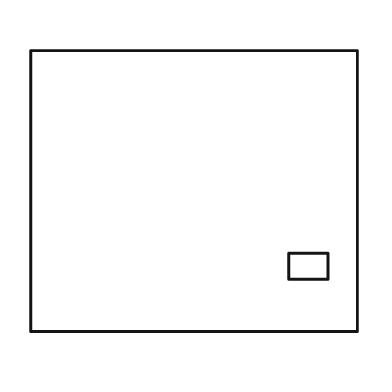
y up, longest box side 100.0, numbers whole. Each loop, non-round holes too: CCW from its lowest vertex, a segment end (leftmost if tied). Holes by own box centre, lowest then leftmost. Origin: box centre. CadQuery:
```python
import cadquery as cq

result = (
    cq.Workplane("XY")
    .moveTo(-50.0, -43.0)
    .lineTo(50.0, -43.0)
    .lineTo(50.0, 43.0)
    .lineTo(-50.0, 43.0)
    .close()
    .moveTo(29.0, -27.0)
    .lineTo(41.0, -27.0)
    .lineTo(41.0, -19.0)
    .lineTo(29.0, -19.0)
    .close()
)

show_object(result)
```